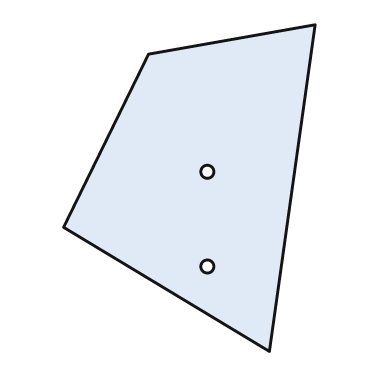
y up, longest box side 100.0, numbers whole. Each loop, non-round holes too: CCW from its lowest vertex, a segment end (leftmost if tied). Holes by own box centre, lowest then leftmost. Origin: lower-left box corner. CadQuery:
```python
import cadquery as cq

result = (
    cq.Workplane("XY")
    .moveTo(63.0, 0.0)
    .lineTo(77.0, 100.0)
    .lineTo(26.0, 91.0)
    .lineTo(0.0, 38.0)
    .close()
    .moveTo(44.0, 26.0)
    .circle(2.0)
    .moveTo(44.0, 55.0)
    .circle(2.0)
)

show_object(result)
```